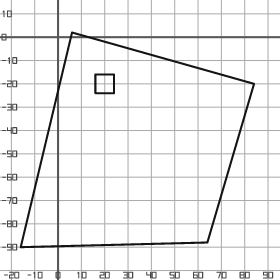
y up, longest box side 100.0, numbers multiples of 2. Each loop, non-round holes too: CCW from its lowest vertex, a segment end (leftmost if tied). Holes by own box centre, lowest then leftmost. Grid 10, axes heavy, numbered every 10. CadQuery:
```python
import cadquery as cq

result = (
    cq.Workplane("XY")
    .moveTo(-16.0, -90.0)
    .lineTo(64.0, -88.0)
    .lineTo(84.0, -20.0)
    .lineTo(6.0, 2.0)
    .close()
    .moveTo(16.0, -24.0)
    .lineTo(24.0, -24.0)
    .lineTo(24.0, -16.0)
    .lineTo(16.0, -16.0)
    .close()
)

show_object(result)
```